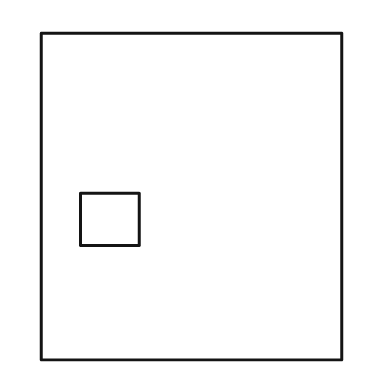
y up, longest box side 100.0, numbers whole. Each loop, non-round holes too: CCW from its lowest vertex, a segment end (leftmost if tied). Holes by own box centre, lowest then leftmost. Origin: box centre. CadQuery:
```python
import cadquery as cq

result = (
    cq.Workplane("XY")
    .moveTo(-46.0, -50.0)
    .lineTo(46.0, -50.0)
    .lineTo(46.0, 50.0)
    .lineTo(-46.0, 50.0)
    .close()
    .moveTo(-34.0, -15.0)
    .lineTo(-16.0, -15.0)
    .lineTo(-16.0, 1.0)
    .lineTo(-34.0, 1.0)
    .close()
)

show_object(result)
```